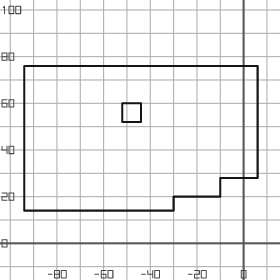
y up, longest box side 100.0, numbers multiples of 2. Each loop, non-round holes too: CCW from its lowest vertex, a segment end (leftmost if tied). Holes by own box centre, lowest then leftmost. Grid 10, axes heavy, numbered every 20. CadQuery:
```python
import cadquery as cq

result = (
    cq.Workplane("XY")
    .moveTo(-94.0, 14.0)
    .lineTo(-30.0, 14.0)
    .lineTo(-30.0, 20.0)
    .lineTo(-10.0, 20.0)
    .lineTo(-10.0, 28.0)
    .lineTo(6.0, 28.0)
    .lineTo(6.0, 76.0)
    .lineTo(-94.0, 76.0)
    .close()
    .moveTo(-52.0, 52.0)
    .lineTo(-44.0, 52.0)
    .lineTo(-44.0, 60.0)
    .lineTo(-52.0, 60.0)
    .close()
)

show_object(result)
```